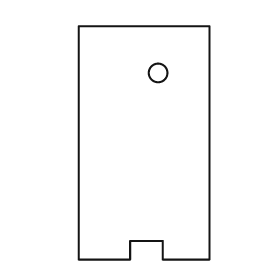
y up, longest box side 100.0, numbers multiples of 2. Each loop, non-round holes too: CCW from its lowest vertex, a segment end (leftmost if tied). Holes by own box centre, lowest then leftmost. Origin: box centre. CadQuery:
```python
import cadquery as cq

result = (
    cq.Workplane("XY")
    .moveTo(-28.0, -50.0)
    .lineTo(-6.0, -50.0)
    .lineTo(-6.0, -42.0)
    .lineTo(8.0, -42.0)
    .lineTo(8.0, -50.0)
    .lineTo(28.0, -50.0)
    .lineTo(28.0, 50.0)
    .lineTo(-28.0, 50.0)
    .close()
    .moveTo(6.0, 30.0)
    .circle(4.0)
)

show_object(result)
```